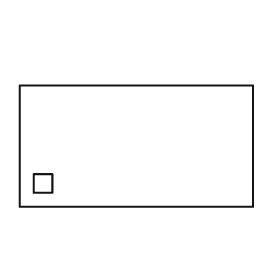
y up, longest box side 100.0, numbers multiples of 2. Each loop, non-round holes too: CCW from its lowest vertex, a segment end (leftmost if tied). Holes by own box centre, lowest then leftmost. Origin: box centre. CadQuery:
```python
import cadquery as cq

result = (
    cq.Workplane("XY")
    .moveTo(-50.0, -26.0)
    .lineTo(50.0, -26.0)
    .lineTo(50.0, 26.0)
    .lineTo(-50.0, 26.0)
    .close()
    .moveTo(-44.0, -20.0)
    .lineTo(-36.0, -20.0)
    .lineTo(-36.0, -12.0)
    .lineTo(-44.0, -12.0)
    .close()
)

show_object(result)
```